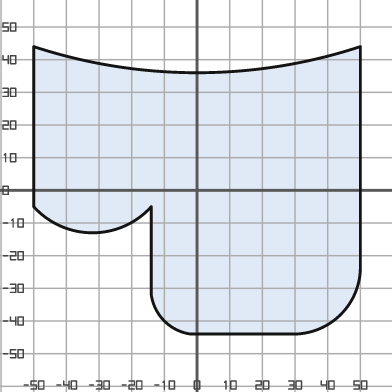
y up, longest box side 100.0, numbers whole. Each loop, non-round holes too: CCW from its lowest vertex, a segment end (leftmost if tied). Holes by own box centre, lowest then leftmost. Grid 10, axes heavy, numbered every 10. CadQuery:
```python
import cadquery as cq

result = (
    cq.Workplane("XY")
    .moveTo(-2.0, -44.0)
    .lineTo(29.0, -44.0)
    .threePointArc((44.0, -38.0), (50.0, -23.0))
    .lineTo(50.0, 44.0)
    .threePointArc((0.0, 36.0), (-50.0, 44.0))
    .lineTo(-50.0, -5.0)
    .threePointArc((-32.0, -13.0), (-14.0, -5.0))
    .lineTo(-14.0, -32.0)
    .threePointArc((-10.0, -40.0), (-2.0, -44.0))
    .close()
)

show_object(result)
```